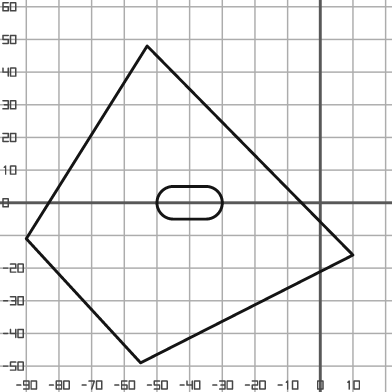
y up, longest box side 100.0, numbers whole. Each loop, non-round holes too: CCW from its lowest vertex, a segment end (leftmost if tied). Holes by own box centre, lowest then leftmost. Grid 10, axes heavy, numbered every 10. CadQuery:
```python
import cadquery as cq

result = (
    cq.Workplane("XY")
    .moveTo(-55.0, -49.0)
    .lineTo(10.0, -16.0)
    .lineTo(-53.0, 48.0)
    .lineTo(-90.0, -11.0)
    .close()
    .moveTo(-45.0, -5.0)
    .lineTo(-35.0, -5.0)
    .threePointArc((-30.0, 0.0), (-35.0, 5.0))
    .lineTo(-45.0, 5.0)
    .threePointArc((-50.0, 0.0), (-45.0, -5.0))
    .close()
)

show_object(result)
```